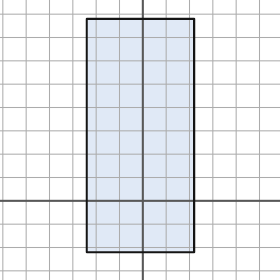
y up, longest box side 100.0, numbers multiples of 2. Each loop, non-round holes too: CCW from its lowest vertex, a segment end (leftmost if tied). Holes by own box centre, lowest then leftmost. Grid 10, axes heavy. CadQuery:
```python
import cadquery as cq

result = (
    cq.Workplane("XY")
    .moveTo(-24.0, -22.0)
    .lineTo(22.0, -22.0)
    .lineTo(22.0, 78.0)
    .lineTo(-24.0, 78.0)
    .close()
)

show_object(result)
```